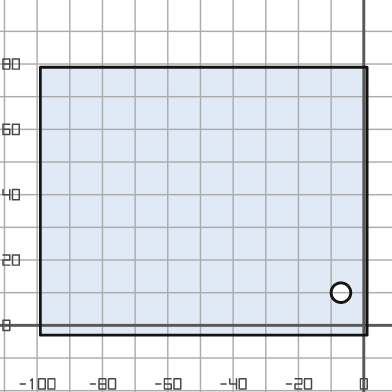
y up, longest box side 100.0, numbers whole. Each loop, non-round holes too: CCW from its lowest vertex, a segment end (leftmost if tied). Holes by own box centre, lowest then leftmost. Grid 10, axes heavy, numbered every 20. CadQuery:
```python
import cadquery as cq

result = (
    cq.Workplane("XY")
    .moveTo(-99.0, -3.0)
    .lineTo(1.0, -3.0)
    .lineTo(1.0, 79.0)
    .lineTo(-99.0, 79.0)
    .close()
    .moveTo(-7.0, 10.0)
    .circle(3.0)
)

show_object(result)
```